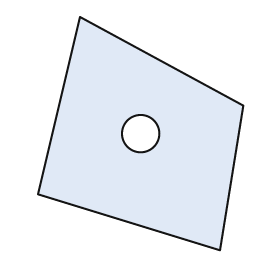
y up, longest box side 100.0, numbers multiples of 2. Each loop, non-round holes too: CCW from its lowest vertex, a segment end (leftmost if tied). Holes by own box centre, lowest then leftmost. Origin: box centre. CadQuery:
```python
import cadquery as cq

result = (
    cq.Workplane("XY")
    .moveTo(34.0, -50.0)
    .lineTo(44.0, 12.0)
    .lineTo(-26.0, 50.0)
    .lineTo(-44.0, -26.0)
    .close()
    .moveTo(0.0, 0.0)
    .circle(8.0)
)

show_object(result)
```